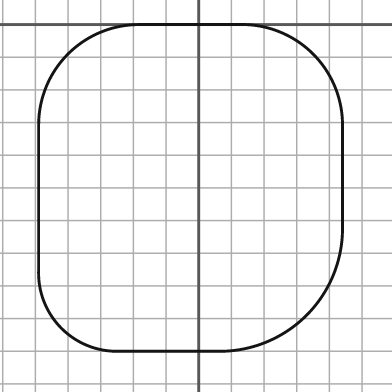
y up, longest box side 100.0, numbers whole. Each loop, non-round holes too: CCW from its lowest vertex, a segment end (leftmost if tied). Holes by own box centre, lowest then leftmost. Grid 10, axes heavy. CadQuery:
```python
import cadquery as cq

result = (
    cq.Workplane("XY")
    .moveTo(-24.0, -100.0)
    .lineTo(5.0, -100.0)
    .threePointArc((33.0, -89.0), (44.0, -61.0))
    .lineTo(44.0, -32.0)
    .threePointArc((35.0, -9.0), (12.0, 0.0))
    .lineTo(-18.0, 0.0)
    .threePointArc((-40.0, -9.0), (-49.0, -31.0))
    .lineTo(-49.0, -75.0)
    .threePointArc((-42.0, -93.0), (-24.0, -100.0))
    .close()
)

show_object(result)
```